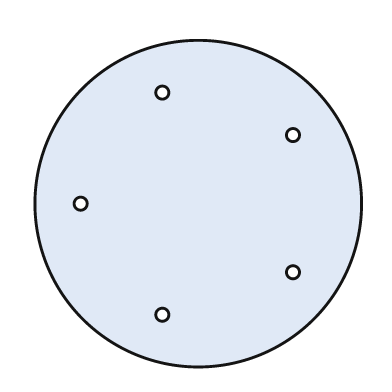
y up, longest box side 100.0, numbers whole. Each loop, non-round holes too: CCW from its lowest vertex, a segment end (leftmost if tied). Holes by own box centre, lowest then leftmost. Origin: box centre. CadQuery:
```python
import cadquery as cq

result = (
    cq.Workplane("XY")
    .moveTo(0.0, 0.0)
    .circle(50.0)
    .moveTo(-11.0, -34.0)
    .circle(2.0)
    .moveTo(29.0, -21.0)
    .circle(2.0)
    .moveTo(-36.0, 0.0)
    .circle(2.0)
    .moveTo(29.0, 21.0)
    .circle(2.0)
    .moveTo(-11.0, 34.0)
    .circle(2.0)
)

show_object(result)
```